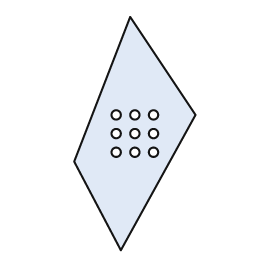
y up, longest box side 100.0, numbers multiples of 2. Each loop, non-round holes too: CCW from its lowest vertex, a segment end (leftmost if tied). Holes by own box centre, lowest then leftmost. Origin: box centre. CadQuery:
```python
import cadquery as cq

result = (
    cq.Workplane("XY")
    .moveTo(-6.0, -50.0)
    .lineTo(26.0, 8.0)
    .lineTo(-2.0, 50.0)
    .lineTo(-26.0, -12.0)
    .close()
    .moveTo(-8.0, -8.0)
    .circle(2.0)
    .moveTo(0.0, -8.0)
    .circle(2.0)
    .moveTo(8.0, -8.0)
    .circle(2.0)
    .moveTo(-8.0, 0.0)
    .circle(2.0)
    .moveTo(0.0, 0.0)
    .circle(2.0)
    .moveTo(8.0, 0.0)
    .circle(2.0)
    .moveTo(-8.0, 8.0)
    .circle(2.0)
    .moveTo(0.0, 8.0)
    .circle(2.0)
    .moveTo(8.0, 8.0)
    .circle(2.0)
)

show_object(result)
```